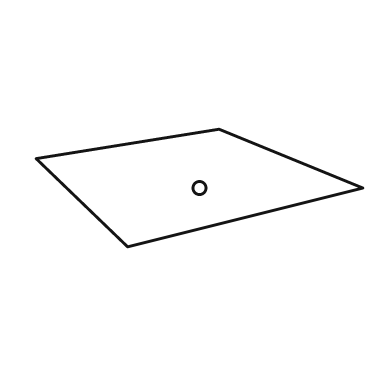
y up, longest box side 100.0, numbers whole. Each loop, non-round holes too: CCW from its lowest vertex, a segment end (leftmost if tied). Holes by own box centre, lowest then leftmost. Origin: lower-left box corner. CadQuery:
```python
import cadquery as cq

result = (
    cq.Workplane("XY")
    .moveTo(28.0, 0.0)
    .lineTo(100.0, 18.0)
    .lineTo(56.0, 36.0)
    .lineTo(0.0, 27.0)
    .close()
    .moveTo(50.0, 18.0)
    .circle(2.0)
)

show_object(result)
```